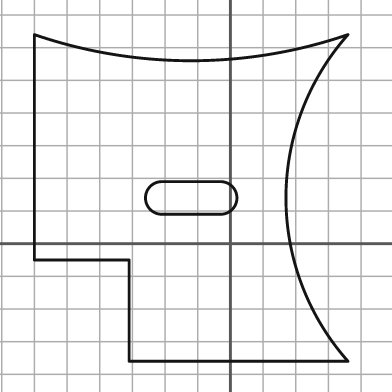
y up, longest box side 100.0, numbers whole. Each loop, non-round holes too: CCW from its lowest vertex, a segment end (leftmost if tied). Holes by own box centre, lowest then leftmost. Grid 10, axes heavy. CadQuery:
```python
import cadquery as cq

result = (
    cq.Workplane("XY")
    .moveTo(-31.0, -36.0)
    .lineTo(36.0, -36.0)
    .threePointArc((17.0, 14.0), (36.0, 64.0))
    .threePointArc((-12.0, 56.0), (-60.0, 64.0))
    .lineTo(-60.0, -5.0)
    .lineTo(-31.0, -5.0)
    .close()
    .moveTo(-21.0, 9.0)
    .lineTo(-3.0, 9.0)
    .threePointArc((2.0, 14.0), (-3.0, 19.0))
    .lineTo(-21.0, 19.0)
    .threePointArc((-26.0, 14.0), (-21.0, 9.0))
    .close()
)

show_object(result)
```